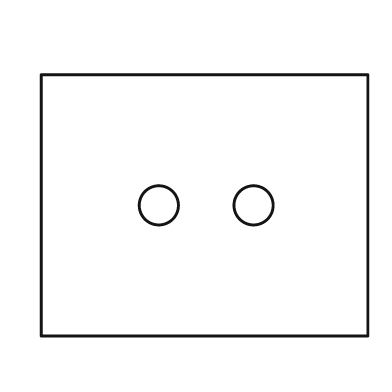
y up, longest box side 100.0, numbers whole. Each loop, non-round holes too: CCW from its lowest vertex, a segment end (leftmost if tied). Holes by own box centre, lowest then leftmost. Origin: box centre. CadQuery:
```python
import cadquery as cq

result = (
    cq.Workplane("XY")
    .moveTo(-50.0, -40.0)
    .lineTo(50.0, -40.0)
    .lineTo(50.0, 40.0)
    .lineTo(-50.0, 40.0)
    .close()
    .moveTo(-14.0, 0.0)
    .circle(6.0)
    .moveTo(15.0, 0.0)
    .circle(6.0)
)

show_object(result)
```